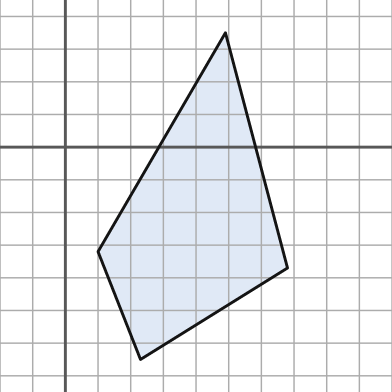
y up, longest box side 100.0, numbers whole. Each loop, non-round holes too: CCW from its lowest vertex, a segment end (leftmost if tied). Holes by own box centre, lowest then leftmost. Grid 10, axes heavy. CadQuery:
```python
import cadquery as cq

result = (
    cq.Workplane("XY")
    .moveTo(23.0, -65.0)
    .lineTo(68.0, -37.0)
    .lineTo(49.0, 35.0)
    .lineTo(10.0, -32.0)
    .close()
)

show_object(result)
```